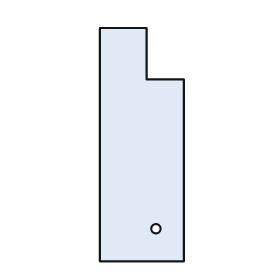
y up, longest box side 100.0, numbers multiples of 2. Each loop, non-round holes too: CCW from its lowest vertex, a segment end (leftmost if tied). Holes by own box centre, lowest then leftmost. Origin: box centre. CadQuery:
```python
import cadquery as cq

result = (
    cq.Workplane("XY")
    .moveTo(-18.0, -50.0)
    .lineTo(18.0, -50.0)
    .lineTo(18.0, 28.0)
    .lineTo(2.0, 28.0)
    .lineTo(2.0, 50.0)
    .lineTo(-18.0, 50.0)
    .close()
    .moveTo(6.0, -36.0)
    .circle(2.0)
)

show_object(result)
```